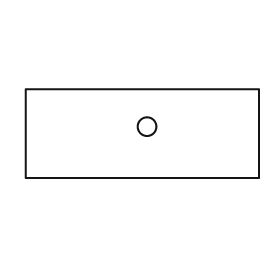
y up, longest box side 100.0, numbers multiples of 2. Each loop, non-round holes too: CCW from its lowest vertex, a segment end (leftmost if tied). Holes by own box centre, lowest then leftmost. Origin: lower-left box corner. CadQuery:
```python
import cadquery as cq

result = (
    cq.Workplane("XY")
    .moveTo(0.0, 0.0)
    .lineTo(100.0, 0.0)
    .lineTo(100.0, 38.0)
    .lineTo(0.0, 38.0)
    .close()
    .moveTo(52.0, 22.0)
    .circle(4.0)
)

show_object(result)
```